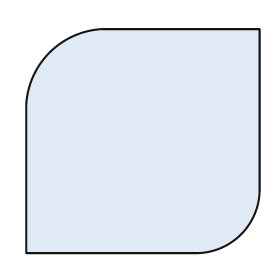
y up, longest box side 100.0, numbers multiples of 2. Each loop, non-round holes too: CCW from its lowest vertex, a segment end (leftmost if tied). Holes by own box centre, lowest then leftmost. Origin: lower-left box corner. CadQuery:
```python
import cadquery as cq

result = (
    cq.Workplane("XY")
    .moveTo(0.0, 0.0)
    .lineTo(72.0, 0.0)
    .threePointArc((92.0, 8.0), (100.0, 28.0))
    .lineTo(100.0, 96.0)
    .lineTo(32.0, 96.0)
    .threePointArc((10.0, 86.0), (0.0, 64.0))
    .close()
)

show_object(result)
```